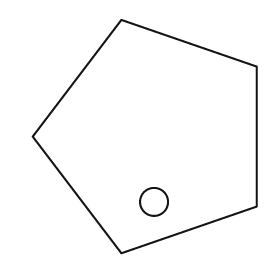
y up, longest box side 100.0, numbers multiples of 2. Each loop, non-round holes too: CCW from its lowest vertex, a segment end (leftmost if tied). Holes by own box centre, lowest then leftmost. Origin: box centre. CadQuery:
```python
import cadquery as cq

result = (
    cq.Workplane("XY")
    .moveTo(-10.0, -50.0)
    .lineTo(48.0, -30.0)
    .lineTo(48.0, 30.0)
    .lineTo(-10.0, 50.0)
    .lineTo(-48.0, 0.0)
    .close()
    .moveTo(4.0, -28.0)
    .circle(6.0)
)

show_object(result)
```